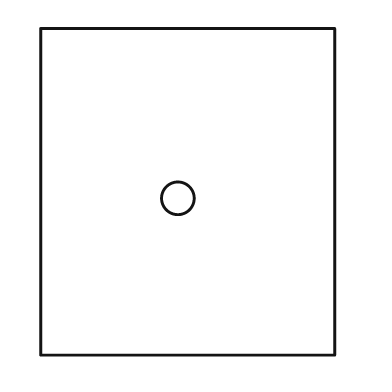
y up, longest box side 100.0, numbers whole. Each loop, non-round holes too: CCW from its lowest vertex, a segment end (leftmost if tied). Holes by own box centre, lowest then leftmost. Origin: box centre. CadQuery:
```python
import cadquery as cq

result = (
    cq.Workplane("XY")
    .moveTo(-45.0, -50.0)
    .lineTo(45.0, -50.0)
    .lineTo(45.0, 50.0)
    .lineTo(-45.0, 50.0)
    .close()
    .moveTo(-3.0, -2.0)
    .circle(5.0)
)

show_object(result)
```